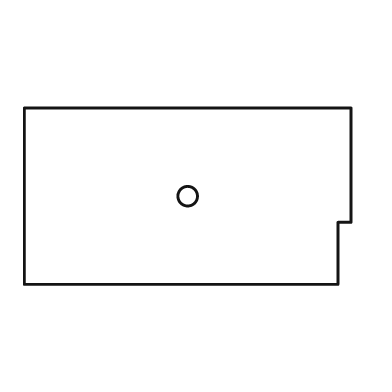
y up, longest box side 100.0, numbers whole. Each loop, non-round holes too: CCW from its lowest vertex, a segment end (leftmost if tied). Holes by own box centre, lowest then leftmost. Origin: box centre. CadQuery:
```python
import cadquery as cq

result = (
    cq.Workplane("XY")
    .moveTo(-50.0, -27.0)
    .lineTo(46.0, -27.0)
    .lineTo(46.0, -8.0)
    .lineTo(50.0, -8.0)
    .lineTo(50.0, 27.0)
    .lineTo(-50.0, 27.0)
    .close()
    .moveTo(0.0, 0.0)
    .circle(3.0)
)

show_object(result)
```